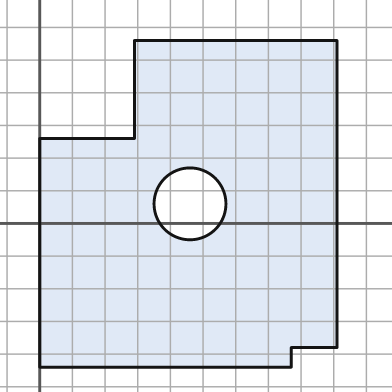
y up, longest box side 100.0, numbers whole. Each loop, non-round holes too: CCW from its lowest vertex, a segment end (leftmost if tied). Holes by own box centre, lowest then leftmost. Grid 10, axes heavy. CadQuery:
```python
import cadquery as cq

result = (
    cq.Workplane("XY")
    .moveTo(0.0, -44.0)
    .lineTo(77.0, -44.0)
    .lineTo(77.0, -38.0)
    .lineTo(91.0, -38.0)
    .lineTo(91.0, 56.0)
    .lineTo(29.0, 56.0)
    .lineTo(29.0, 26.0)
    .lineTo(0.0, 26.0)
    .close()
    .moveTo(46.0, 6.0)
    .circle(11.0)
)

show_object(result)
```